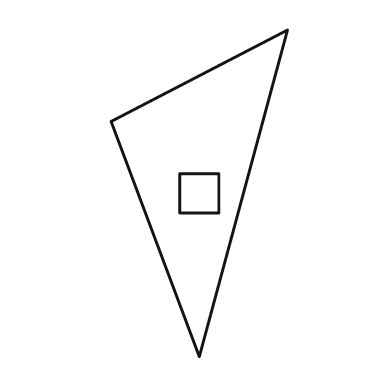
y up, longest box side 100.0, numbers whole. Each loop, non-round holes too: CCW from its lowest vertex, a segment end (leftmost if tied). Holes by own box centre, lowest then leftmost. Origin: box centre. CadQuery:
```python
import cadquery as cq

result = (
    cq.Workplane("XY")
    .moveTo(0.0, -50.0)
    .lineTo(27.0, 50.0)
    .lineTo(-27.0, 22.0)
    .close()
    .moveTo(-6.0, -6.0)
    .lineTo(6.0, -6.0)
    .lineTo(6.0, 6.0)
    .lineTo(-6.0, 6.0)
    .close()
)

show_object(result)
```